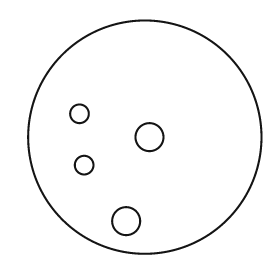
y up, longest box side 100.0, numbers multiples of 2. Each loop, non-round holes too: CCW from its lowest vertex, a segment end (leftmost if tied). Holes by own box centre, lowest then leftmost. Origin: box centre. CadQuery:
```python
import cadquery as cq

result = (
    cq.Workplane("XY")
    .moveTo(0.0, 0.0)
    .circle(50.0)
    .moveTo(-8.0, -36.0)
    .circle(6.0)
    .moveTo(-26.0, -12.0)
    .circle(4.0)
    .moveTo(2.0, 0.0)
    .circle(6.0)
    .moveTo(-28.0, 10.0)
    .circle(4.0)
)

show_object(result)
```